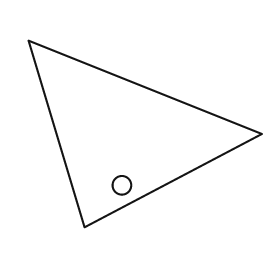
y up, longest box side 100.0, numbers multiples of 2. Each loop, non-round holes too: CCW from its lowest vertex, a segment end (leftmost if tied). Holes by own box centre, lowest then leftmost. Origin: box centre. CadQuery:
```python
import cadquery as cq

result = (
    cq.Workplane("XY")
    .moveTo(-26.0, -40.0)
    .lineTo(50.0, 0.0)
    .lineTo(-50.0, 40.0)
    .close()
    .moveTo(-10.0, -22.0)
    .circle(4.0)
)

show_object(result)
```